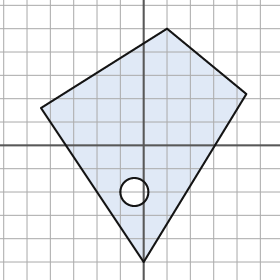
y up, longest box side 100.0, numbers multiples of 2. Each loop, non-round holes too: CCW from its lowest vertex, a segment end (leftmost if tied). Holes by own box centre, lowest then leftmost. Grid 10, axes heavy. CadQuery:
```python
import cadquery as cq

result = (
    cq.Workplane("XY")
    .moveTo(0.0, -50.0)
    .lineTo(44.0, 22.0)
    .lineTo(10.0, 50.0)
    .lineTo(-44.0, 16.0)
    .close()
    .moveTo(-4.0, -20.0)
    .circle(6.0)
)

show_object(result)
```